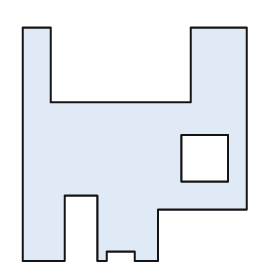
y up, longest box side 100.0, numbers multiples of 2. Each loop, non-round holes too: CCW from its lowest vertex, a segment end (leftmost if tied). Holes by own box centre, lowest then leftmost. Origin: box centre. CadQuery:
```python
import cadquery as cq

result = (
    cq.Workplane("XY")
    .moveTo(-48.0, -50.0)
    .lineTo(-30.0, -50.0)
    .lineTo(-30.0, -22.0)
    .lineTo(-16.0, -22.0)
    .lineTo(-16.0, -50.0)
    .lineTo(-12.0, -50.0)
    .lineTo(-12.0, -46.0)
    .lineTo(0.0, -46.0)
    .lineTo(0.0, -50.0)
    .lineTo(10.0, -50.0)
    .lineTo(10.0, -28.0)
    .lineTo(48.0, -28.0)
    .lineTo(48.0, 50.0)
    .lineTo(24.0, 50.0)
    .lineTo(24.0, 18.0)
    .lineTo(-36.0, 18.0)
    .lineTo(-36.0, 50.0)
    .lineTo(-48.0, 50.0)
    .close()
    .moveTo(20.0, -16.0)
    .lineTo(40.0, -16.0)
    .lineTo(40.0, 4.0)
    .lineTo(20.0, 4.0)
    .close()
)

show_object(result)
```